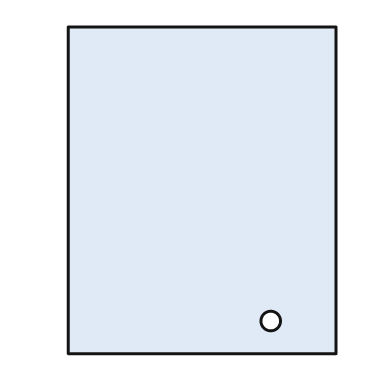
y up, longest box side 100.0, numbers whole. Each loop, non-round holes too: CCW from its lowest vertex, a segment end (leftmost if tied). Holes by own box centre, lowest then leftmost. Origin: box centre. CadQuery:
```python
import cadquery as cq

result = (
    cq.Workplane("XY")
    .moveTo(-41.0, -50.0)
    .lineTo(41.0, -50.0)
    .lineTo(41.0, 50.0)
    .lineTo(-41.0, 50.0)
    .close()
    .moveTo(21.0, -40.0)
    .circle(3.0)
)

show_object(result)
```